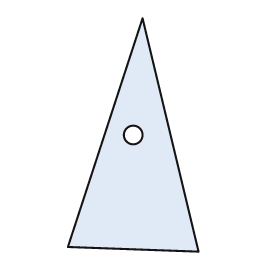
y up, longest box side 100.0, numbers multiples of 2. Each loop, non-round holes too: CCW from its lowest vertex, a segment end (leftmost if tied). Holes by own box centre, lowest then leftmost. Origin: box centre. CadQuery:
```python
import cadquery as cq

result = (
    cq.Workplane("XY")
    .moveTo(28.0, -50.0)
    .lineTo(4.0, 50.0)
    .lineTo(-28.0, -48.0)
    .close()
    .moveTo(0.0, 0.0)
    .circle(4.0)
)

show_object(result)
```